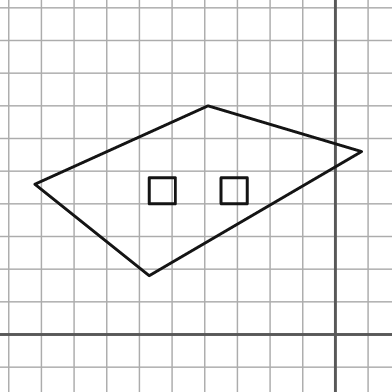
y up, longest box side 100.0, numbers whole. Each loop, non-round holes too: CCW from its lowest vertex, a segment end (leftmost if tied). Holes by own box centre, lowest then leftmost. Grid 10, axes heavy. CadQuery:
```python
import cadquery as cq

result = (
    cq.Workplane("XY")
    .moveTo(-57.0, 18.0)
    .lineTo(8.0, 56.0)
    .lineTo(-39.0, 70.0)
    .lineTo(-92.0, 46.0)
    .close()
    .moveTo(-57.0, 40.0)
    .lineTo(-49.0, 40.0)
    .lineTo(-49.0, 48.0)
    .lineTo(-57.0, 48.0)
    .close()
    .moveTo(-35.0, 40.0)
    .lineTo(-27.0, 40.0)
    .lineTo(-27.0, 48.0)
    .lineTo(-35.0, 48.0)
    .close()
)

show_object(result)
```